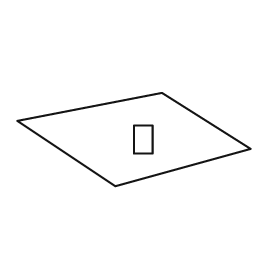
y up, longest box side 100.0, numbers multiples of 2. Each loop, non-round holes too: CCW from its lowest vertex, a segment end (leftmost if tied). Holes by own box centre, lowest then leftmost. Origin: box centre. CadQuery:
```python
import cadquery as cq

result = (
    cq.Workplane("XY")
    .moveTo(-8.0, -20.0)
    .lineTo(50.0, -4.0)
    .lineTo(12.0, 20.0)
    .lineTo(-50.0, 8.0)
    .close()
    .moveTo(0.0, -6.0)
    .lineTo(8.0, -6.0)
    .lineTo(8.0, 6.0)
    .lineTo(0.0, 6.0)
    .close()
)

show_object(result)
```